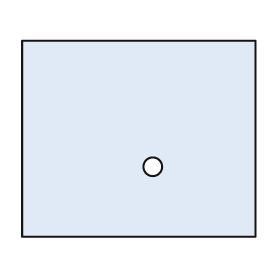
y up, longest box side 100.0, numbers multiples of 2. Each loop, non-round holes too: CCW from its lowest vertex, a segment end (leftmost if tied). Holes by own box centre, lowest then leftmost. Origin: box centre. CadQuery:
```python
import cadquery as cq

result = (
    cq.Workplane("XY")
    .moveTo(-50.0, -42.0)
    .lineTo(50.0, -42.0)
    .lineTo(50.0, 42.0)
    .lineTo(-50.0, 42.0)
    .close()
    .moveTo(6.0, -12.0)
    .circle(4.0)
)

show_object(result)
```